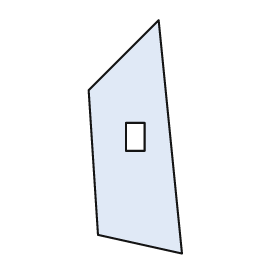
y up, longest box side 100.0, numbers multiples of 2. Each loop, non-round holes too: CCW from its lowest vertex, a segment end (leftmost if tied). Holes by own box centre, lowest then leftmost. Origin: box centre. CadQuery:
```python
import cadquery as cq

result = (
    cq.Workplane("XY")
    .moveTo(20.0, -50.0)
    .lineTo(10.0, 50.0)
    .lineTo(-20.0, 20.0)
    .lineTo(-16.0, -42.0)
    .close()
    .moveTo(-4.0, -6.0)
    .lineTo(4.0, -6.0)
    .lineTo(4.0, 6.0)
    .lineTo(-4.0, 6.0)
    .close()
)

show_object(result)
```